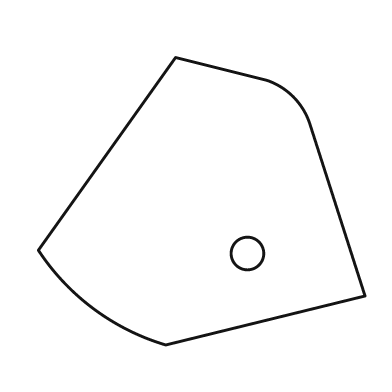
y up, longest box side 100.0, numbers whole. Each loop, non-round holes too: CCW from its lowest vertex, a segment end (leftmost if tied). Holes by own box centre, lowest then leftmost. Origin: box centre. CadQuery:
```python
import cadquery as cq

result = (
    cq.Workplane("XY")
    .moveTo(-11.0, -44.0)
    .lineTo(50.0, -29.0)
    .lineTo(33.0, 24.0)
    .threePointArc((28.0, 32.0), (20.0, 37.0))
    .lineTo(-8.0, 44.0)
    .lineTo(-50.0, -15.0)
    .threePointArc((-33.0, -33.0), (-11.0, -44.0))
    .close()
    .moveTo(14.0, -16.0)
    .circle(5.0)
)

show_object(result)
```